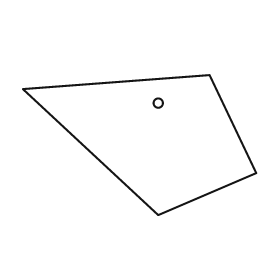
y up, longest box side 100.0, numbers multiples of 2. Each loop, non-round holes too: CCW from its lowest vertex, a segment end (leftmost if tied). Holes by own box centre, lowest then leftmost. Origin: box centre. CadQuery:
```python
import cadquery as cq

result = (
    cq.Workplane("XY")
    .moveTo(8.0, -30.0)
    .lineTo(50.0, -12.0)
    .lineTo(30.0, 30.0)
    .lineTo(-50.0, 24.0)
    .close()
    .moveTo(8.0, 18.0)
    .circle(2.0)
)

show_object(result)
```